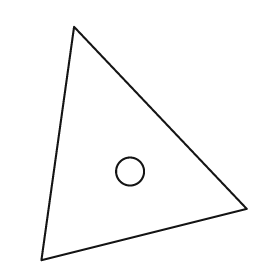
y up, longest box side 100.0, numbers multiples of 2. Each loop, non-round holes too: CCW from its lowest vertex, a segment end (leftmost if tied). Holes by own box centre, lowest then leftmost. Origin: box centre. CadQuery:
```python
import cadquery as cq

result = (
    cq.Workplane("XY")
    .moveTo(-44.0, -50.0)
    .lineTo(44.0, -28.0)
    .lineTo(-30.0, 50.0)
    .close()
    .moveTo(-6.0, -12.0)
    .circle(6.0)
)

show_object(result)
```